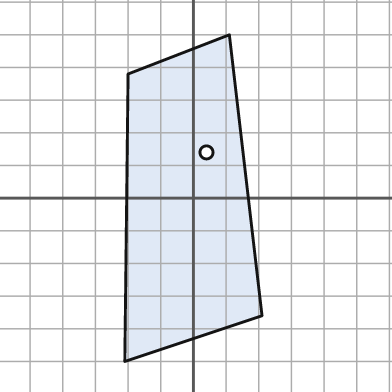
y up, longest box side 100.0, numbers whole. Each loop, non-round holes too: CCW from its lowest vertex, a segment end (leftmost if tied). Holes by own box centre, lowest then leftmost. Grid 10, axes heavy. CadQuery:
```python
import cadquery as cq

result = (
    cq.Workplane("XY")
    .moveTo(-21.0, -50.0)
    .lineTo(21.0, -36.0)
    .lineTo(11.0, 50.0)
    .lineTo(-20.0, 38.0)
    .close()
    .moveTo(4.0, 14.0)
    .circle(2.0)
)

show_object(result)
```